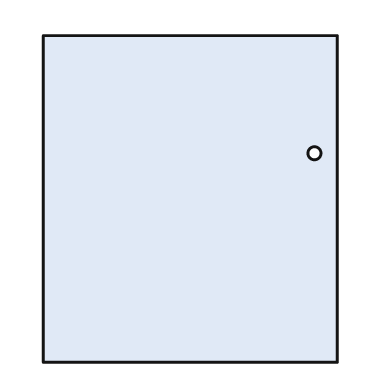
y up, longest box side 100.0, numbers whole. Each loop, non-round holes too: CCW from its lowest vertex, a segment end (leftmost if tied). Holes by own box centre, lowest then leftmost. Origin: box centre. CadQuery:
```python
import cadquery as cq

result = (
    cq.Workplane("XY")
    .moveTo(-45.0, -50.0)
    .lineTo(45.0, -50.0)
    .lineTo(45.0, 50.0)
    .lineTo(-45.0, 50.0)
    .close()
    .moveTo(38.0, 14.0)
    .circle(2.0)
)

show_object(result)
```